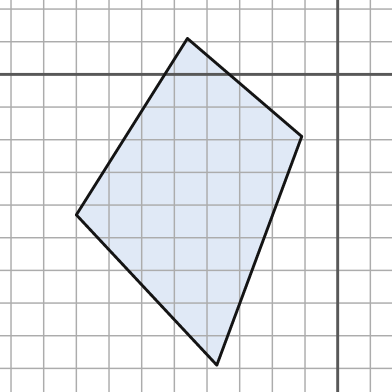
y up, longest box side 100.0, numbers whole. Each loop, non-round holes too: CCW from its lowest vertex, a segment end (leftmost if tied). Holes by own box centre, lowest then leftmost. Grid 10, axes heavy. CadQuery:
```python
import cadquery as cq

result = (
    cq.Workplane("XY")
    .moveTo(-37.0, -89.0)
    .lineTo(-11.0, -19.0)
    .lineTo(-46.0, 11.0)
    .lineTo(-80.0, -43.0)
    .close()
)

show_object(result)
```